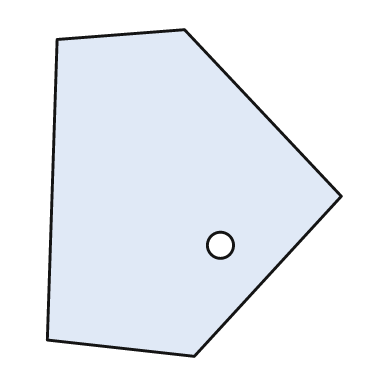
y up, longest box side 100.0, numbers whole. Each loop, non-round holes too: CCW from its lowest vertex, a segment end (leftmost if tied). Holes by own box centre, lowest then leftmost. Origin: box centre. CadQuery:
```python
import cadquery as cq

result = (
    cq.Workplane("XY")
    .moveTo(0.0, -50.0)
    .lineTo(45.0, -1.0)
    .lineTo(-3.0, 50.0)
    .lineTo(-42.0, 47.0)
    .lineTo(-45.0, -45.0)
    .close()
    .moveTo(8.0, -16.0)
    .circle(4.0)
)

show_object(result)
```